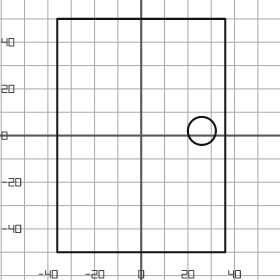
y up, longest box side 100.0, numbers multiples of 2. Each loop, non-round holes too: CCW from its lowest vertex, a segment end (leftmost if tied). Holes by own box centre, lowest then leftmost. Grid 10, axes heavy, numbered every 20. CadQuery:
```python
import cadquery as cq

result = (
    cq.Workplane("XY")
    .moveTo(-36.0, -50.0)
    .lineTo(36.0, -50.0)
    .lineTo(36.0, 50.0)
    .lineTo(-36.0, 50.0)
    .close()
    .moveTo(26.0, 2.0)
    .circle(6.0)
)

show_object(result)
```